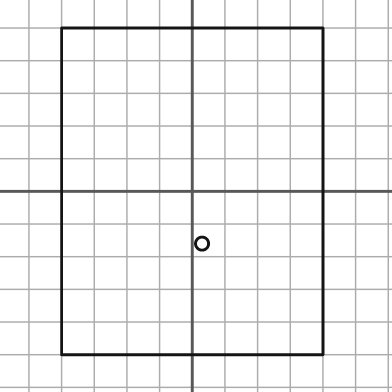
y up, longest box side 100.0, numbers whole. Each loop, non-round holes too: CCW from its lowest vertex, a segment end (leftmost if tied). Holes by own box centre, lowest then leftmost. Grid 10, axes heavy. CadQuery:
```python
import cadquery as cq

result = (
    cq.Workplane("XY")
    .moveTo(-40.0, -50.0)
    .lineTo(40.0, -50.0)
    .lineTo(40.0, 50.0)
    .lineTo(-40.0, 50.0)
    .close()
    .moveTo(3.0, -16.0)
    .circle(2.0)
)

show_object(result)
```